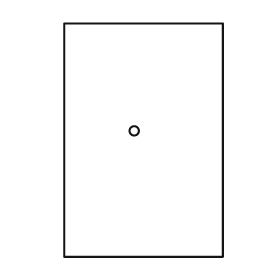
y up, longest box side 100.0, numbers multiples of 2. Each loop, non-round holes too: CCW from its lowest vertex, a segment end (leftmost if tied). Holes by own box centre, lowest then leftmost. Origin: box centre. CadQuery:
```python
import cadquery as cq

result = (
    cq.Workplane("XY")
    .moveTo(-34.0, -50.0)
    .lineTo(34.0, -50.0)
    .lineTo(34.0, 50.0)
    .lineTo(-34.0, 50.0)
    .close()
    .moveTo(-4.0, 4.0)
    .circle(2.0)
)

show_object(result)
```